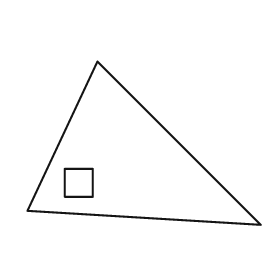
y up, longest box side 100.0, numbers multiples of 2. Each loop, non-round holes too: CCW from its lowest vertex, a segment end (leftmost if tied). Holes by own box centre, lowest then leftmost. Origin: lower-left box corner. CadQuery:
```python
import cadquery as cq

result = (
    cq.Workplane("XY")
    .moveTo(100.0, 0.0)
    .lineTo(30.0, 70.0)
    .lineTo(0.0, 6.0)
    .close()
    .moveTo(16.0, 12.0)
    .lineTo(28.0, 12.0)
    .lineTo(28.0, 24.0)
    .lineTo(16.0, 24.0)
    .close()
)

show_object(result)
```